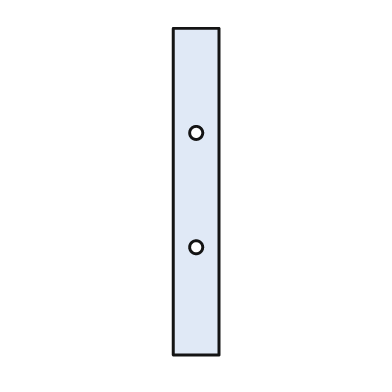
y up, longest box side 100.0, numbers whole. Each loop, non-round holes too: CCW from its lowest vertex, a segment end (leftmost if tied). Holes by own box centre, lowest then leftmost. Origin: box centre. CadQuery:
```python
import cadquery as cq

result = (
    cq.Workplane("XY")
    .moveTo(-7.0, -50.0)
    .lineTo(7.0, -50.0)
    .lineTo(7.0, 50.0)
    .lineTo(-7.0, 50.0)
    .close()
    .moveTo(0.0, -17.0)
    .circle(2.0)
    .moveTo(0.0, 18.0)
    .circle(2.0)
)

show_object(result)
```